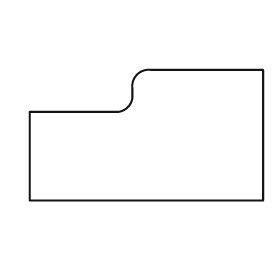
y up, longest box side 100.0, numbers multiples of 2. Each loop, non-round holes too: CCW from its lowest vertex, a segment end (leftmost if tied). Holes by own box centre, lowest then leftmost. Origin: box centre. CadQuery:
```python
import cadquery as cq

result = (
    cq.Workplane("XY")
    .moveTo(-50.0, -28.0)
    .lineTo(50.0, -28.0)
    .lineTo(50.0, 28.0)
    .lineTo(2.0, 28.0)
    .threePointArc((-4.0, 26.0), (-6.0, 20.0))
    .lineTo(-6.0, 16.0)
    .threePointArc((-8.0, 12.0), (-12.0, 10.0))
    .lineTo(-50.0, 10.0)
    .close()
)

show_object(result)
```